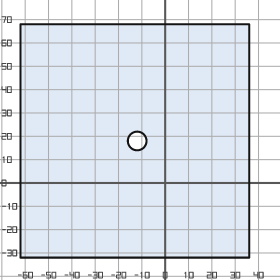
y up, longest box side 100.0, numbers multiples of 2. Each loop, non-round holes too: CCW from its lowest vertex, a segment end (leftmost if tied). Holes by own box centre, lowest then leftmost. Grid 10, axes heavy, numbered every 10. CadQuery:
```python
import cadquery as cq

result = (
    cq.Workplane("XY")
    .moveTo(-62.0, -32.0)
    .lineTo(36.0, -32.0)
    .lineTo(36.0, 68.0)
    .lineTo(-62.0, 68.0)
    .close()
    .moveTo(-12.0, 18.0)
    .circle(4.0)
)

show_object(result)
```